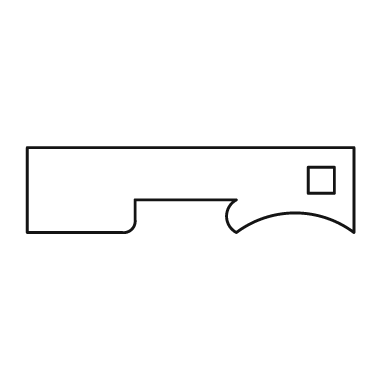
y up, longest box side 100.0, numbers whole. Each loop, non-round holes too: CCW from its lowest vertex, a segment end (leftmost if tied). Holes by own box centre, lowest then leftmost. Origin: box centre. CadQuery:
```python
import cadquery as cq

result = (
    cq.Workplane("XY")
    .moveTo(-50.0, -13.0)
    .lineTo(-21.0, -13.0)
    .threePointArc((-18.0, -12.0), (-17.0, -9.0))
    .lineTo(-17.0, -3.0)
    .lineTo(14.0, -3.0)
    .threePointArc((11.0, -8.0), (14.0, -13.0))
    .threePointArc((32.0, -7.0), (50.0, -13.0))
    .lineTo(50.0, 13.0)
    .lineTo(-50.0, 13.0)
    .close()
    .moveTo(36.0, -1.0)
    .lineTo(44.0, -1.0)
    .lineTo(44.0, 7.0)
    .lineTo(36.0, 7.0)
    .close()
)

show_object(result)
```